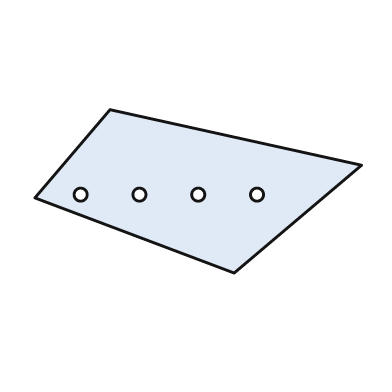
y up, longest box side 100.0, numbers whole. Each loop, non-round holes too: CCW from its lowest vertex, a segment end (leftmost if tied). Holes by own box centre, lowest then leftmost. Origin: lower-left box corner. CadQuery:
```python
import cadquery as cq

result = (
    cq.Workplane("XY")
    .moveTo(61.0, 0.0)
    .lineTo(100.0, 33.0)
    .lineTo(23.0, 50.0)
    .lineTo(0.0, 23.0)
    .close()
    .moveTo(14.0, 24.0)
    .circle(2.0)
    .moveTo(32.0, 24.0)
    .circle(2.0)
    .moveTo(50.0, 24.0)
    .circle(2.0)
    .moveTo(68.0, 24.0)
    .circle(2.0)
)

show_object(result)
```